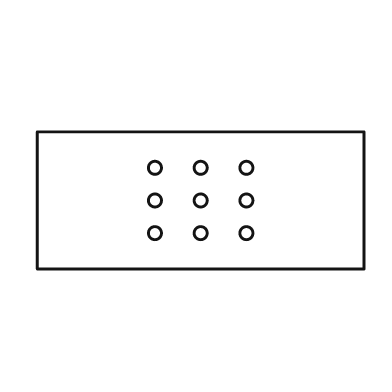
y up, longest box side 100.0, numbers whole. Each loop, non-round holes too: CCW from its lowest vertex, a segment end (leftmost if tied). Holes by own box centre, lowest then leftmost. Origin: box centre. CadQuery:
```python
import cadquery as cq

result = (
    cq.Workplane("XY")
    .moveTo(-50.0, -21.0)
    .lineTo(50.0, -21.0)
    .lineTo(50.0, 21.0)
    .lineTo(-50.0, 21.0)
    .close()
    .moveTo(-14.0, -10.0)
    .circle(2.0)
    .moveTo(0.0, -10.0)
    .circle(2.0)
    .moveTo(14.0, -10.0)
    .circle(2.0)
    .moveTo(-14.0, 0.0)
    .circle(2.0)
    .moveTo(0.0, 0.0)
    .circle(2.0)
    .moveTo(14.0, 0.0)
    .circle(2.0)
    .moveTo(-14.0, 10.0)
    .circle(2.0)
    .moveTo(0.0, 10.0)
    .circle(2.0)
    .moveTo(14.0, 10.0)
    .circle(2.0)
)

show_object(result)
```